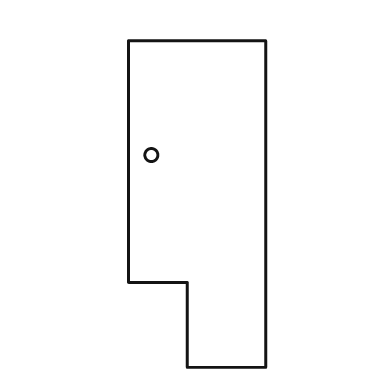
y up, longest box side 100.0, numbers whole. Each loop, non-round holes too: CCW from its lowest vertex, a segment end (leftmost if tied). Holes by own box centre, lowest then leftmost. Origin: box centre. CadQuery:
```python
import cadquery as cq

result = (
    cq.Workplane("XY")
    .moveTo(-3.0, -50.0)
    .lineTo(21.0, -50.0)
    .lineTo(21.0, 50.0)
    .lineTo(-21.0, 50.0)
    .lineTo(-21.0, -24.0)
    .lineTo(-3.0, -24.0)
    .close()
    .moveTo(-14.0, 15.0)
    .circle(2.0)
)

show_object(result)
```